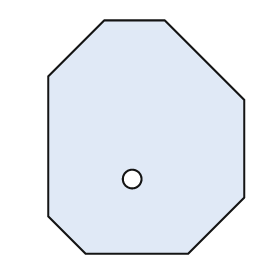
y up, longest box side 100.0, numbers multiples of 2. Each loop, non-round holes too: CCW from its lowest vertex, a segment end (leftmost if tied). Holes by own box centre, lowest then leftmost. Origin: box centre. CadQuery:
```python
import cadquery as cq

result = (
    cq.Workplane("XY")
    .moveTo(-26.0, -50.0)
    .lineTo(18.0, -50.0)
    .lineTo(42.0, -26.0)
    .lineTo(42.0, 16.0)
    .lineTo(8.0, 50.0)
    .lineTo(-18.0, 50.0)
    .lineTo(-42.0, 26.0)
    .lineTo(-42.0, -34.0)
    .close()
    .moveTo(-6.0, -18.0)
    .circle(4.0)
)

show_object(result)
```